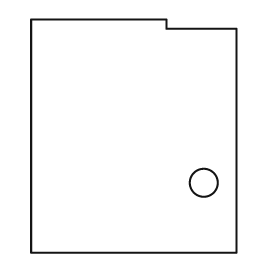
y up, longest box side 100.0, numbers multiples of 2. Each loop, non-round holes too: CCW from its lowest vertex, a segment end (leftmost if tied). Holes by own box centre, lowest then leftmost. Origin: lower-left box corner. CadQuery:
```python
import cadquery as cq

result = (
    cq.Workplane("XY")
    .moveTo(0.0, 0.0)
    .lineTo(88.0, 0.0)
    .lineTo(88.0, 96.0)
    .lineTo(58.0, 96.0)
    .lineTo(58.0, 100.0)
    .lineTo(0.0, 100.0)
    .close()
    .moveTo(74.0, 30.0)
    .circle(6.0)
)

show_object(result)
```